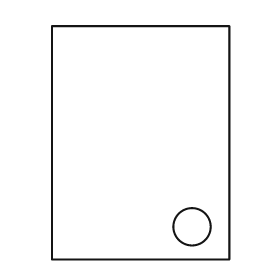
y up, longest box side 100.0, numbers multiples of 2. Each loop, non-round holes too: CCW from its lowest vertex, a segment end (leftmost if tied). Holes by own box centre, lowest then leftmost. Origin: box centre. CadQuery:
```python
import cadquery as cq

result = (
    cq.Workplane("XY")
    .moveTo(-38.0, -50.0)
    .lineTo(38.0, -50.0)
    .lineTo(38.0, 50.0)
    .lineTo(-38.0, 50.0)
    .close()
    .moveTo(22.0, -36.0)
    .circle(8.0)
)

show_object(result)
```